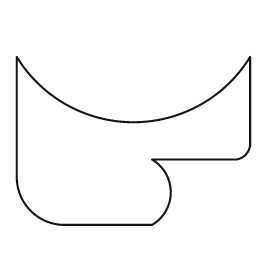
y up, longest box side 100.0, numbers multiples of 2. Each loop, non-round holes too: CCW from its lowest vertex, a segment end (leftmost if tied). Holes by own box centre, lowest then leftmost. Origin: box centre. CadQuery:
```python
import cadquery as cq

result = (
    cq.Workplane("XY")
    .moveTo(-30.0, -36.0)
    .lineTo(8.0, -36.0)
    .threePointArc((16.0, -22.0), (8.0, -8.0))
    .lineTo(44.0, -8.0)
    .threePointArc((48.0, -6.0), (50.0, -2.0))
    .lineTo(50.0, 36.0)
    .threePointArc((0.0, 8.0), (-50.0, 36.0))
    .lineTo(-50.0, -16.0)
    .threePointArc((-44.0, -30.0), (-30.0, -36.0))
    .close()
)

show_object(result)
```